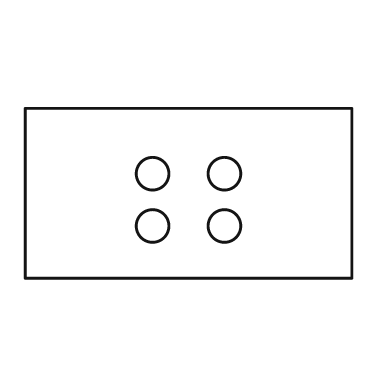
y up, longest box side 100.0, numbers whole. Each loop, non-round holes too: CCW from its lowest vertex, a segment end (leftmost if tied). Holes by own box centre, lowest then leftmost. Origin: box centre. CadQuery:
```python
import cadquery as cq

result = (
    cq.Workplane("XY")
    .moveTo(-50.0, -26.0)
    .lineTo(50.0, -26.0)
    .lineTo(50.0, 26.0)
    .lineTo(-50.0, 26.0)
    .close()
    .moveTo(-11.0, -10.0)
    .circle(5.0)
    .moveTo(11.0, -10.0)
    .circle(5.0)
    .moveTo(-11.0, 6.0)
    .circle(5.0)
    .moveTo(11.0, 6.0)
    .circle(5.0)
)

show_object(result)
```